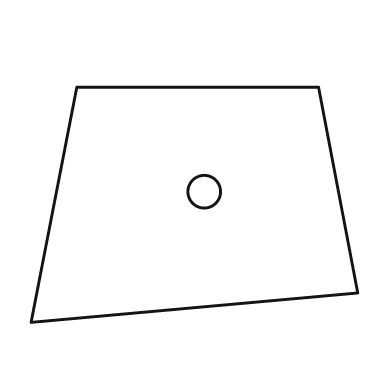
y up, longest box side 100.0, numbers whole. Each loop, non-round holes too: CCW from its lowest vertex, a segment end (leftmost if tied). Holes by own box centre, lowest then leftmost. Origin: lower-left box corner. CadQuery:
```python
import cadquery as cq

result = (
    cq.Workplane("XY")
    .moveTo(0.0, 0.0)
    .lineTo(100.0, 9.0)
    .lineTo(88.0, 72.0)
    .lineTo(14.0, 72.0)
    .close()
    .moveTo(53.0, 40.0)
    .circle(5.0)
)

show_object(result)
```